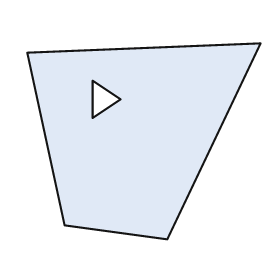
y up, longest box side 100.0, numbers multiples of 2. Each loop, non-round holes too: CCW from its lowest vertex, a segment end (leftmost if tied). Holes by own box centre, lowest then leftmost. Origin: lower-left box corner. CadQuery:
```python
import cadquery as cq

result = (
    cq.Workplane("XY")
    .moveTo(60.0, 0.0)
    .lineTo(100.0, 84.0)
    .lineTo(0.0, 80.0)
    .lineTo(16.0, 6.0)
    .close()
    .moveTo(28.0, 52.0)
    .lineTo(40.0, 60.0)
    .lineTo(28.0, 68.0)
    .close()
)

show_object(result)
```